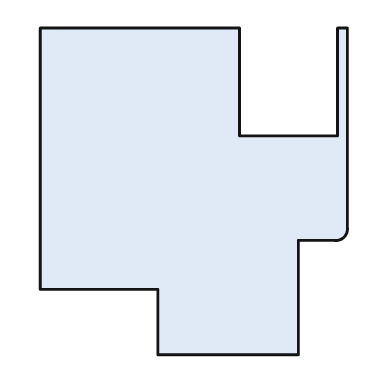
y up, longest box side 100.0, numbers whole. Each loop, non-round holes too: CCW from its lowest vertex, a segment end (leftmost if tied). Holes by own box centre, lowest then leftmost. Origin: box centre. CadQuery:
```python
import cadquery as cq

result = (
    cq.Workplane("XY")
    .moveTo(-11.0, -50.0)
    .lineTo(32.0, -50.0)
    .lineTo(32.0, -15.0)
    .lineTo(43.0, -15.0)
    .threePointArc((46.0, -14.0), (47.0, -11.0))
    .lineTo(47.0, 50.0)
    .lineTo(44.0, 50.0)
    .lineTo(44.0, 17.0)
    .lineTo(14.0, 17.0)
    .lineTo(14.0, 50.0)
    .lineTo(-47.0, 50.0)
    .lineTo(-47.0, -30.0)
    .lineTo(-11.0, -30.0)
    .close()
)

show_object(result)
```